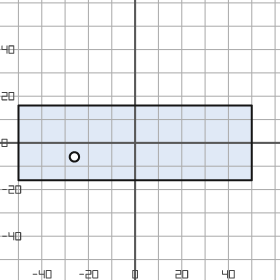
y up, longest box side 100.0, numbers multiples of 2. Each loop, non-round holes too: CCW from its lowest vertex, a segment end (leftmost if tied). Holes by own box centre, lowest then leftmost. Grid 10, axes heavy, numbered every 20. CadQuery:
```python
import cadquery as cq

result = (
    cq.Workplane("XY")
    .moveTo(-50.0, -16.0)
    .lineTo(50.0, -16.0)
    .lineTo(50.0, 16.0)
    .lineTo(-50.0, 16.0)
    .close()
    .moveTo(-26.0, -6.0)
    .circle(2.0)
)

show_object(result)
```